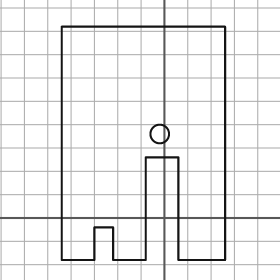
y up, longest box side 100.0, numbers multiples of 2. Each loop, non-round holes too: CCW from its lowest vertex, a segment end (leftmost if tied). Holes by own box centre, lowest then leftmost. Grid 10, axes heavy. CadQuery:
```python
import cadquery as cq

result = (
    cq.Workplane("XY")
    .moveTo(-44.0, -18.0)
    .lineTo(-30.0, -18.0)
    .lineTo(-30.0, -4.0)
    .lineTo(-22.0, -4.0)
    .lineTo(-22.0, -18.0)
    .lineTo(-8.0, -18.0)
    .lineTo(-8.0, 26.0)
    .lineTo(6.0, 26.0)
    .lineTo(6.0, -18.0)
    .lineTo(26.0, -18.0)
    .lineTo(26.0, 82.0)
    .lineTo(-44.0, 82.0)
    .close()
    .moveTo(-2.0, 36.0)
    .circle(4.0)
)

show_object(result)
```